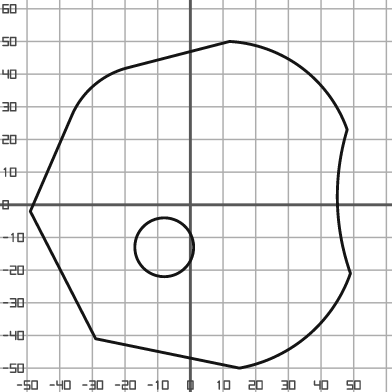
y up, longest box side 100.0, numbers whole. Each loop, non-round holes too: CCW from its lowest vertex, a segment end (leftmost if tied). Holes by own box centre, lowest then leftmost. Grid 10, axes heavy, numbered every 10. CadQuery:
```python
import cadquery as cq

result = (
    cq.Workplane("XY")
    .moveTo(15.0, -50.0)
    .threePointArc((36.0, -40.0), (49.0, -21.0))
    .threePointArc((45.0, 1.0), (48.0, 23.0))
    .threePointArc((34.0, 42.0), (12.0, 50.0))
    .lineTo(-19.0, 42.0)
    .threePointArc((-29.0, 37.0), (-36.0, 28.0))
    .lineTo(-49.0, -2.0)
    .lineTo(-29.0, -41.0)
    .close()
    .moveTo(-8.0, -13.0)
    .circle(9.0)
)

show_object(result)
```